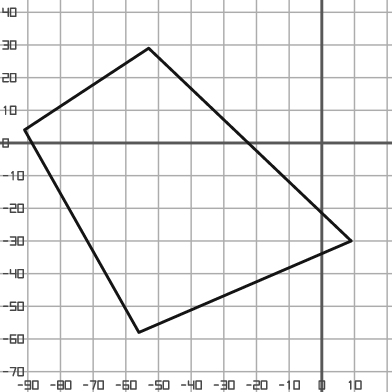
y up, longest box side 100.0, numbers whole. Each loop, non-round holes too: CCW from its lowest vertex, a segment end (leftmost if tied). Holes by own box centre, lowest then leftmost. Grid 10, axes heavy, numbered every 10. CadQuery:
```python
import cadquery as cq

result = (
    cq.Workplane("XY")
    .moveTo(-56.0, -58.0)
    .lineTo(9.0, -30.0)
    .lineTo(-53.0, 29.0)
    .lineTo(-91.0, 4.0)
    .close()
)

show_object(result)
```